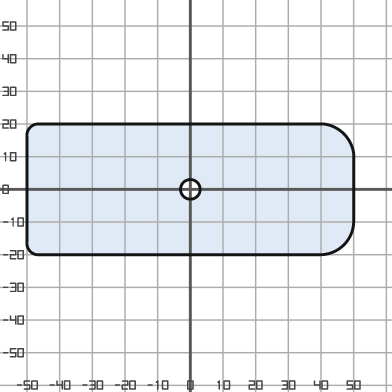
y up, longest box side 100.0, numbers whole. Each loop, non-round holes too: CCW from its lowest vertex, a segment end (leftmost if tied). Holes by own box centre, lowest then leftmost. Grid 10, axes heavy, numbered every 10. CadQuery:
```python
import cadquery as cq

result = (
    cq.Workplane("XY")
    .moveTo(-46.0, -20.0)
    .lineTo(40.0, -20.0)
    .threePointArc((47.0, -17.0), (50.0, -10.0))
    .lineTo(50.0, 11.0)
    .threePointArc((47.0, 17.0), (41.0, 20.0))
    .lineTo(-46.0, 20.0)
    .threePointArc((-49.0, 19.0), (-50.0, 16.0))
    .lineTo(-50.0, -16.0)
    .threePointArc((-49.0, -19.0), (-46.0, -20.0))
    .close()
    .moveTo(0.0, 0.0)
    .circle(3.0)
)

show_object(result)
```